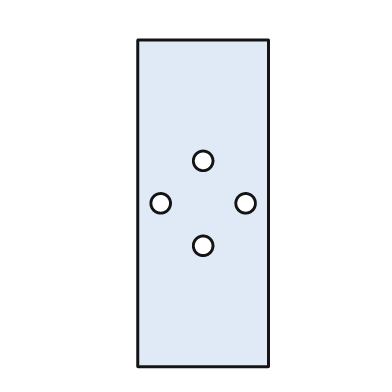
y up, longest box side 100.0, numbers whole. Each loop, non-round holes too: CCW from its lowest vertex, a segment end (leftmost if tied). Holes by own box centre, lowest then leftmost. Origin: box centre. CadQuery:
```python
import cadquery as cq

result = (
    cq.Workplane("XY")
    .moveTo(-20.0, -50.0)
    .lineTo(20.0, -50.0)
    .lineTo(20.0, 50.0)
    .lineTo(-20.0, 50.0)
    .close()
    .moveTo(0.0, -13.0)
    .circle(3.0)
    .moveTo(-13.0, 0.0)
    .circle(3.0)
    .moveTo(13.0, 0.0)
    .circle(3.0)
    .moveTo(0.0, 13.0)
    .circle(3.0)
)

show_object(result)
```